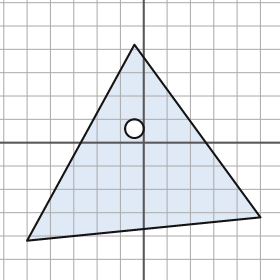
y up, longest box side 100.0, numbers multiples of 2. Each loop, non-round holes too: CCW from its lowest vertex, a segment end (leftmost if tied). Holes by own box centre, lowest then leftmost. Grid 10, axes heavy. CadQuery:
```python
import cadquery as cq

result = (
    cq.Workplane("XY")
    .moveTo(-50.0, -42.0)
    .lineTo(50.0, -32.0)
    .lineTo(-4.0, 42.0)
    .close()
    .moveTo(-4.0, 6.0)
    .circle(4.0)
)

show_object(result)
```